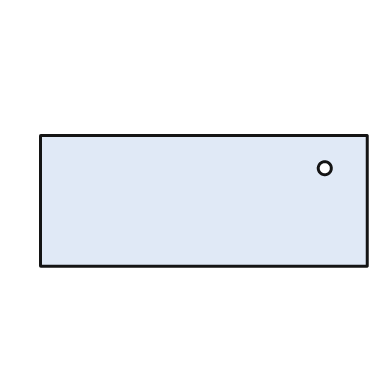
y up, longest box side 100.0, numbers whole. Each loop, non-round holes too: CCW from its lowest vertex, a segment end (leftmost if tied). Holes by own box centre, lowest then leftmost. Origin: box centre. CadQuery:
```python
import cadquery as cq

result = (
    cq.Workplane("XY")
    .moveTo(-50.0, -20.0)
    .lineTo(50.0, -20.0)
    .lineTo(50.0, 20.0)
    .lineTo(-50.0, 20.0)
    .close()
    .moveTo(37.0, 10.0)
    .circle(2.0)
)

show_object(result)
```